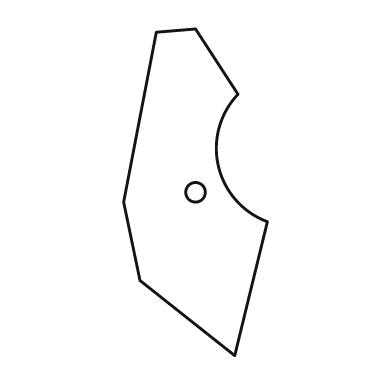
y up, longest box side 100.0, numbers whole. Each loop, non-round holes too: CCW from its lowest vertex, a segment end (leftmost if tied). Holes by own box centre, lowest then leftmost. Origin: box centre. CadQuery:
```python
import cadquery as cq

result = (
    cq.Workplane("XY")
    .moveTo(12.0, -50.0)
    .lineTo(22.0, -9.0)
    .threePointArc((7.0, 8.0), (13.0, 30.0))
    .lineTo(0.0, 50.0)
    .lineTo(-12.0, 49.0)
    .lineTo(-22.0, -3.0)
    .lineTo(-17.0, -27.0)
    .close()
    .moveTo(0.0, 0.0)
    .circle(3.0)
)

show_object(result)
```